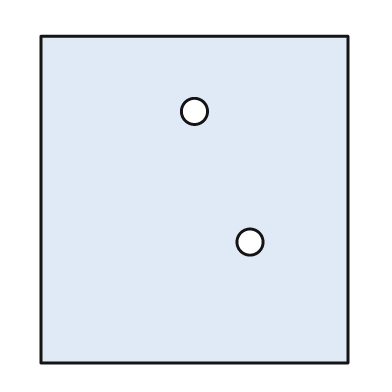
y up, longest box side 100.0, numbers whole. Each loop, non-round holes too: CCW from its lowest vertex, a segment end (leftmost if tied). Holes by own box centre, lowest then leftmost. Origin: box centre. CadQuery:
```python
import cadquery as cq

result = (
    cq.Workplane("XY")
    .moveTo(-47.0, -50.0)
    .lineTo(47.0, -50.0)
    .lineTo(47.0, 50.0)
    .lineTo(-47.0, 50.0)
    .close()
    .moveTo(17.0, -13.0)
    .circle(4.0)
    .moveTo(0.0, 27.0)
    .circle(4.0)
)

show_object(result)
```